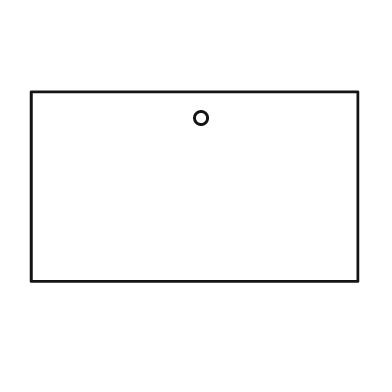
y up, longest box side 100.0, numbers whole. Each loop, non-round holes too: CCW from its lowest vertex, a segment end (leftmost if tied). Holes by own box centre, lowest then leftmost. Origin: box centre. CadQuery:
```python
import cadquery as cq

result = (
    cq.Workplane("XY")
    .moveTo(-50.0, -29.0)
    .lineTo(50.0, -29.0)
    .lineTo(50.0, 29.0)
    .lineTo(-50.0, 29.0)
    .close()
    .moveTo(2.0, 21.0)
    .circle(2.0)
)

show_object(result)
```